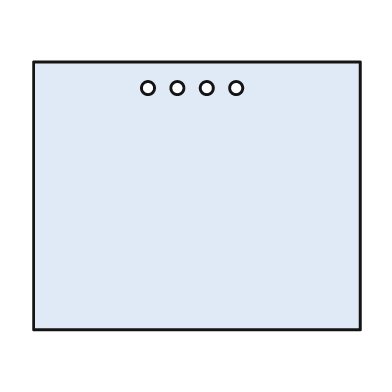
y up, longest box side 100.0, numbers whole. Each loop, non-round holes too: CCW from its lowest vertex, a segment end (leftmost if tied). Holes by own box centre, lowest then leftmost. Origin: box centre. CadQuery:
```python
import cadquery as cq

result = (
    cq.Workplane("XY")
    .moveTo(-50.0, -41.0)
    .lineTo(50.0, -41.0)
    .lineTo(50.0, 41.0)
    .lineTo(-50.0, 41.0)
    .close()
    .moveTo(-15.0, 33.0)
    .circle(2.0)
    .moveTo(-6.0, 33.0)
    .circle(2.0)
    .moveTo(3.0, 33.0)
    .circle(2.0)
    .moveTo(12.0, 33.0)
    .circle(2.0)
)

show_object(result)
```